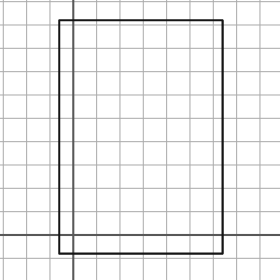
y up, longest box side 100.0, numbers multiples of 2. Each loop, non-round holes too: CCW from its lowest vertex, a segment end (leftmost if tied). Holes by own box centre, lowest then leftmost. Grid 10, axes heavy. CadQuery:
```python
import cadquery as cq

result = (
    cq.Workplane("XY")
    .moveTo(-6.0, -8.0)
    .lineTo(64.0, -8.0)
    .lineTo(64.0, 92.0)
    .lineTo(-6.0, 92.0)
    .close()
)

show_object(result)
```